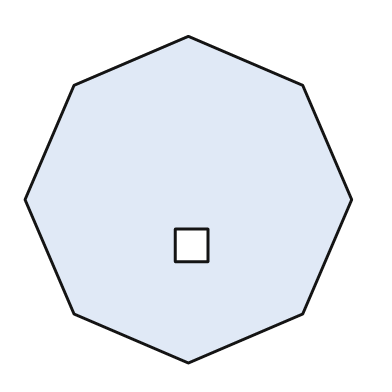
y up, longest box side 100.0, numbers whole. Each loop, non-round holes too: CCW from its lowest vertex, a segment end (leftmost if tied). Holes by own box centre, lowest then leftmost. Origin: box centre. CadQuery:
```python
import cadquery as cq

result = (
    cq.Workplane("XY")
    .moveTo(0.0, -50.0)
    .lineTo(35.0, -35.0)
    .lineTo(50.0, 0.0)
    .lineTo(35.0, 35.0)
    .lineTo(0.0, 50.0)
    .lineTo(-35.0, 35.0)
    .lineTo(-50.0, 0.0)
    .lineTo(-35.0, -35.0)
    .close()
    .moveTo(-4.0, -19.0)
    .lineTo(6.0, -19.0)
    .lineTo(6.0, -9.0)
    .lineTo(-4.0, -9.0)
    .close()
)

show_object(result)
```